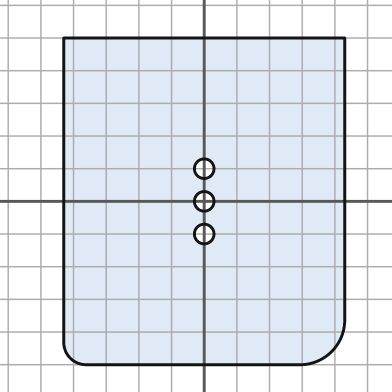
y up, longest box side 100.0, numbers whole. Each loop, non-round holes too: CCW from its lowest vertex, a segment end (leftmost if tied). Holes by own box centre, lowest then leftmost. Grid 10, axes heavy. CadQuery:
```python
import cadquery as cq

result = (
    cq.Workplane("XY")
    .moveTo(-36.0, -50.0)
    .lineTo(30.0, -50.0)
    .threePointArc((39.0, -46.0), (43.0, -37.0))
    .lineTo(43.0, 50.0)
    .lineTo(-43.0, 50.0)
    .lineTo(-43.0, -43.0)
    .threePointArc((-41.0, -48.0), (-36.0, -50.0))
    .close()
    .moveTo(0.0, -10.0)
    .circle(3.0)
    .moveTo(0.0, 0.0)
    .circle(3.0)
    .moveTo(0.0, 10.0)
    .circle(3.0)
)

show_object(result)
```